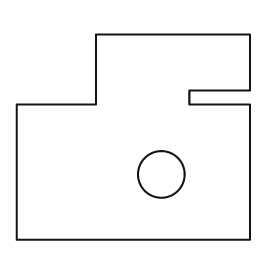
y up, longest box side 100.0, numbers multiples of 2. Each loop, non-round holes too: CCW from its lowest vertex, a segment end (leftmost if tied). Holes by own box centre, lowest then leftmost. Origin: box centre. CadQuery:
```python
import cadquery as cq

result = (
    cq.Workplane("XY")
    .moveTo(-50.0, -44.0)
    .lineTo(50.0, -44.0)
    .lineTo(50.0, 14.0)
    .lineTo(24.0, 14.0)
    .lineTo(24.0, 20.0)
    .lineTo(50.0, 20.0)
    .lineTo(50.0, 44.0)
    .lineTo(-16.0, 44.0)
    .lineTo(-16.0, 14.0)
    .lineTo(-50.0, 14.0)
    .close()
    .moveTo(12.0, -16.0)
    .circle(10.0)
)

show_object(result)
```